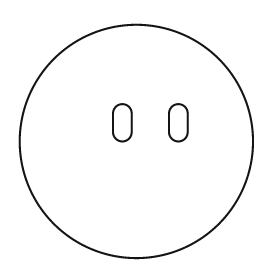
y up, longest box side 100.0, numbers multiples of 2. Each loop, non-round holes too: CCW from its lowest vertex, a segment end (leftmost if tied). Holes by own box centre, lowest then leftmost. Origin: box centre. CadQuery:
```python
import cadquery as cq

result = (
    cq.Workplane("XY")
    .moveTo(0.0, 0.0)
    .circle(50.0)
    .moveTo(-10.0, 4.0)
    .threePointArc((-6.0, 0.0), (-2.0, 4.0))
    .lineTo(-2.0, 12.0)
    .threePointArc((-6.0, 16.0), (-10.0, 12.0))
    .close()
    .moveTo(14.0, 4.0)
    .threePointArc((18.0, 0.0), (22.0, 4.0))
    .lineTo(22.0, 12.0)
    .threePointArc((18.0, 16.0), (14.0, 12.0))
    .close()
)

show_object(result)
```